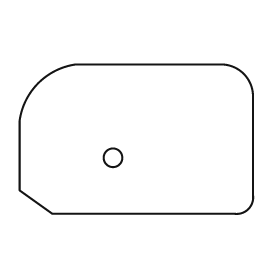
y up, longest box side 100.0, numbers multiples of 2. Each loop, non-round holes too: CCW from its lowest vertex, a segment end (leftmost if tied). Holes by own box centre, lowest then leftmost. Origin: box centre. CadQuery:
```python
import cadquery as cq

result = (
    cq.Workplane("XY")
    .moveTo(-36.0, -32.0)
    .lineTo(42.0, -32.0)
    .threePointArc((48.0, -30.0), (50.0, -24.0))
    .lineTo(50.0, 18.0)
    .threePointArc((46.0, 28.0), (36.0, 32.0))
    .lineTo(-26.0, 32.0)
    .threePointArc((-42.0, 24.0), (-50.0, 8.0))
    .lineTo(-50.0, -22.0)
    .close()
    .moveTo(-10.0, -8.0)
    .circle(4.0)
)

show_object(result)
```